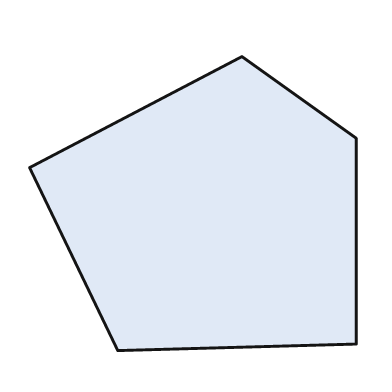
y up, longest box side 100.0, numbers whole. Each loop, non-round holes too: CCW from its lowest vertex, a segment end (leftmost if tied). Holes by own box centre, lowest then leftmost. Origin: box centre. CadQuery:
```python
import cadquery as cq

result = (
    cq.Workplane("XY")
    .moveTo(-23.0, -45.0)
    .lineTo(50.0, -43.0)
    .lineTo(50.0, 20.0)
    .lineTo(15.0, 45.0)
    .lineTo(-50.0, 11.0)
    .close()
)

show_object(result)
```